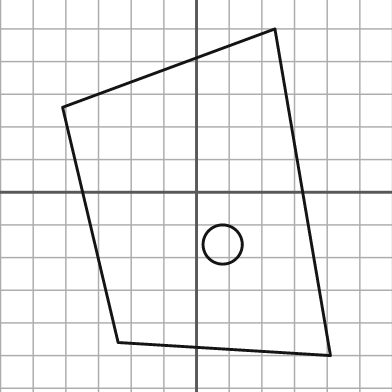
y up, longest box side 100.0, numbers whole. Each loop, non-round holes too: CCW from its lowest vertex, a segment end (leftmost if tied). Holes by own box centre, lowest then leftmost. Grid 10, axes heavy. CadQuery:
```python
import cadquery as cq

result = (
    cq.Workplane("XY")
    .moveTo(41.0, -50.0)
    .lineTo(24.0, 50.0)
    .lineTo(-41.0, 26.0)
    .lineTo(-24.0, -46.0)
    .close()
    .moveTo(8.0, -16.0)
    .circle(6.0)
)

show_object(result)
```